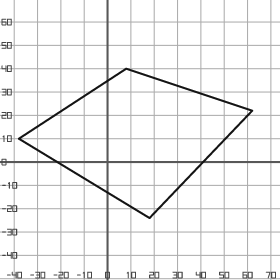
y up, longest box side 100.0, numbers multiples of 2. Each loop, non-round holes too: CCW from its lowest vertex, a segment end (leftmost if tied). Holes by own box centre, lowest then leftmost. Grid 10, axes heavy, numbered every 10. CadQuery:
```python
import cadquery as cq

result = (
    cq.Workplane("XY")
    .moveTo(18.0, -24.0)
    .lineTo(62.0, 22.0)
    .lineTo(8.0, 40.0)
    .lineTo(-38.0, 10.0)
    .close()
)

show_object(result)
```